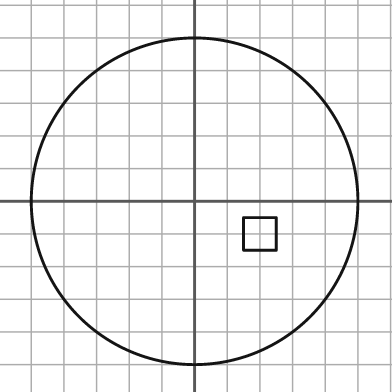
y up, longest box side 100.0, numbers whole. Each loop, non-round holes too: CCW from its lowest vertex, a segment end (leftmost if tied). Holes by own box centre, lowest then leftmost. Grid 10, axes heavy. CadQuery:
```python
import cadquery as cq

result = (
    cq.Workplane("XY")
    .moveTo(0.0, 0.0)
    .circle(50.0)
    .moveTo(15.0, -15.0)
    .lineTo(25.0, -15.0)
    .lineTo(25.0, -5.0)
    .lineTo(15.0, -5.0)
    .close()
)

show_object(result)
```